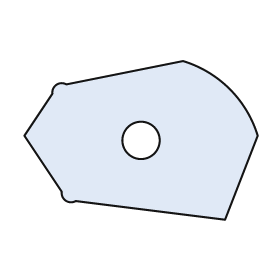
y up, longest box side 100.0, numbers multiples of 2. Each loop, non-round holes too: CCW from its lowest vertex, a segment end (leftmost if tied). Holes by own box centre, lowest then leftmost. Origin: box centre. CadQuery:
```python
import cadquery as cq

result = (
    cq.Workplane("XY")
    .moveTo(36.0, -34.0)
    .lineTo(50.0, 2.0)
    .threePointArc((38.0, 22.0), (18.0, 34.0))
    .lineTo(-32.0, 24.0)
    .threePointArc((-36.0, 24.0), (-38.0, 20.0))
    .lineTo(-50.0, 2.0)
    .lineTo(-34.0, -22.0)
    .threePointArc((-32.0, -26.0), (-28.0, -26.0))
    .close()
    .moveTo(0.0, 0.0)
    .circle(8.0)
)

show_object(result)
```